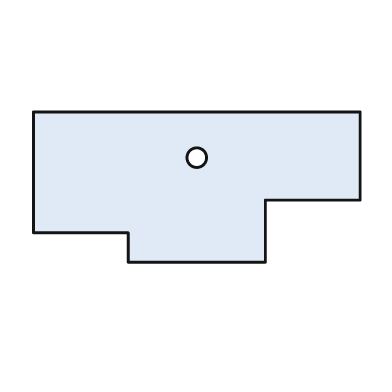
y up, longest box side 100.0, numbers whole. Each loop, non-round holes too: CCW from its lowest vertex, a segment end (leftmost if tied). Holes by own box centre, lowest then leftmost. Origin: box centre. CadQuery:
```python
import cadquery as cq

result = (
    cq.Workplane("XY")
    .moveTo(-21.0, -23.0)
    .lineTo(21.0, -23.0)
    .lineTo(21.0, -4.0)
    .lineTo(50.0, -4.0)
    .lineTo(50.0, 23.0)
    .lineTo(-50.0, 23.0)
    .lineTo(-50.0, -14.0)
    .lineTo(-21.0, -14.0)
    .close()
    .moveTo(0.0, 9.0)
    .circle(3.0)
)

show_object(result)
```